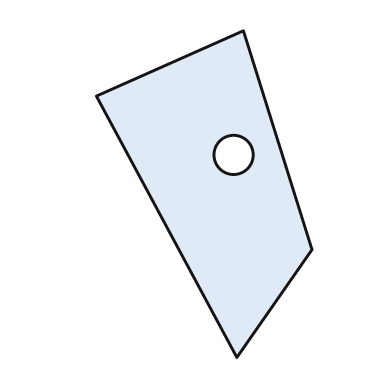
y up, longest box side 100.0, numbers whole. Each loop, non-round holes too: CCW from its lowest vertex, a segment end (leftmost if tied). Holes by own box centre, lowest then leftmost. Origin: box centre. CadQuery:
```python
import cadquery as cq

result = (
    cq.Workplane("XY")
    .moveTo(10.0, -50.0)
    .lineTo(33.0, -17.0)
    .lineTo(12.0, 50.0)
    .lineTo(-33.0, 30.0)
    .close()
    .moveTo(9.0, 12.0)
    .circle(6.0)
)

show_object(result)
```